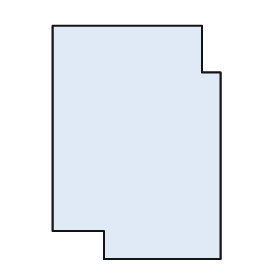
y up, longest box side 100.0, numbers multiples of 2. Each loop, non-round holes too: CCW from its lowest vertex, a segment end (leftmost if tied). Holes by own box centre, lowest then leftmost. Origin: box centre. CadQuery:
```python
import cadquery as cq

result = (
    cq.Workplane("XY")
    .moveTo(-14.0, -50.0)
    .lineTo(36.0, -50.0)
    .lineTo(36.0, 30.0)
    .lineTo(28.0, 30.0)
    .lineTo(28.0, 50.0)
    .lineTo(-36.0, 50.0)
    .lineTo(-36.0, -38.0)
    .lineTo(-14.0, -38.0)
    .close()
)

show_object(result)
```